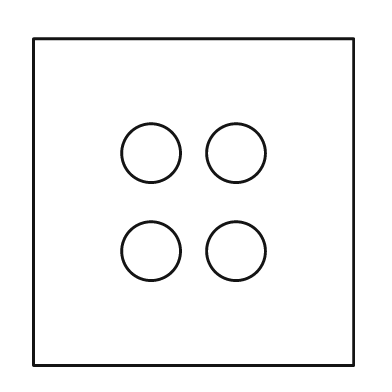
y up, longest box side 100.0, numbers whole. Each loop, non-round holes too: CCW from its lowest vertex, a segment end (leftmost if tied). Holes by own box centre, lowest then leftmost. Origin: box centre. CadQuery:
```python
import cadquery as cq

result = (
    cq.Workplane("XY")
    .moveTo(-49.0, -50.0)
    .lineTo(49.0, -50.0)
    .lineTo(49.0, 50.0)
    .lineTo(-49.0, 50.0)
    .close()
    .moveTo(-13.0, -15.0)
    .circle(9.0)
    .moveTo(13.0, -15.0)
    .circle(9.0)
    .moveTo(-13.0, 15.0)
    .circle(9.0)
    .moveTo(13.0, 15.0)
    .circle(9.0)
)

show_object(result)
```